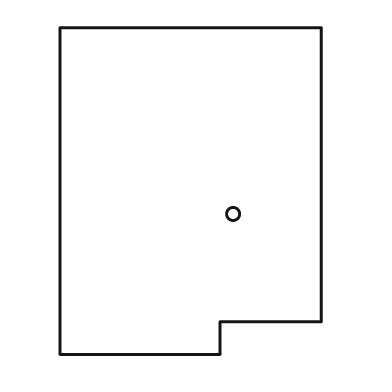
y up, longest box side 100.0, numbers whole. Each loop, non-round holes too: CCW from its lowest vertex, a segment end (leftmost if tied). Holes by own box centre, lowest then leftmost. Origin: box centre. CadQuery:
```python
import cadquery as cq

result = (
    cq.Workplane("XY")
    .moveTo(-40.0, -50.0)
    .lineTo(9.0, -50.0)
    .lineTo(9.0, -40.0)
    .lineTo(40.0, -40.0)
    .lineTo(40.0, 50.0)
    .lineTo(-40.0, 50.0)
    .close()
    .moveTo(13.0, -7.0)
    .circle(2.0)
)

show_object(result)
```